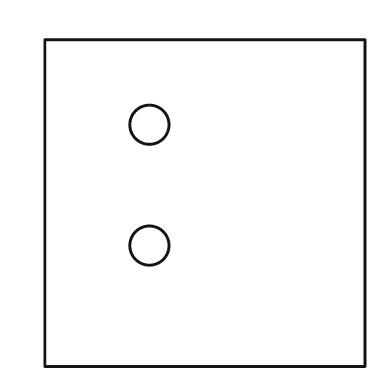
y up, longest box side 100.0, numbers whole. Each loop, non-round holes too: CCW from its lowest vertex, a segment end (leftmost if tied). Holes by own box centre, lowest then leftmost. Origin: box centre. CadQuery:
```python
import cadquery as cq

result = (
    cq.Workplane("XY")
    .moveTo(-49.0, -50.0)
    .lineTo(49.0, -50.0)
    .lineTo(49.0, 50.0)
    .lineTo(-49.0, 50.0)
    .close()
    .moveTo(-17.0, -13.0)
    .circle(6.0)
    .moveTo(-17.0, 24.0)
    .circle(6.0)
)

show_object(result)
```